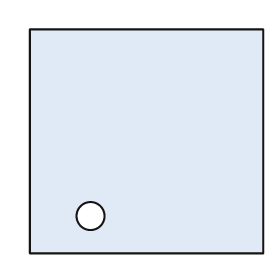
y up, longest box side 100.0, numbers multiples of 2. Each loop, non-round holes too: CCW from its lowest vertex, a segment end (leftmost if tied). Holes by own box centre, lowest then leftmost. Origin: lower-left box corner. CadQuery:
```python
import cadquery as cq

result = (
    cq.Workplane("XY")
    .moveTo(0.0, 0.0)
    .lineTo(100.0, 0.0)
    .lineTo(100.0, 96.0)
    .lineTo(0.0, 96.0)
    .close()
    .moveTo(26.0, 16.0)
    .circle(6.0)
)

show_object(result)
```